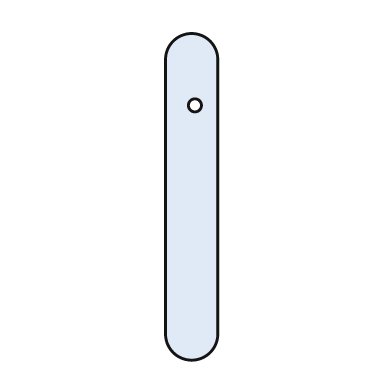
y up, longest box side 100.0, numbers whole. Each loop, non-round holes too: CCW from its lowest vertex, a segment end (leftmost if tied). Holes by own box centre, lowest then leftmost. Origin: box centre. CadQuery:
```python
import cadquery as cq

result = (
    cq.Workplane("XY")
    .moveTo(-8.0, -42.0)
    .threePointArc((0.0, -50.0), (8.0, -42.0))
    .lineTo(8.0, 42.0)
    .threePointArc((0.0, 50.0), (-8.0, 42.0))
    .close()
    .moveTo(1.0, 28.0)
    .circle(2.0)
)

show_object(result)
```